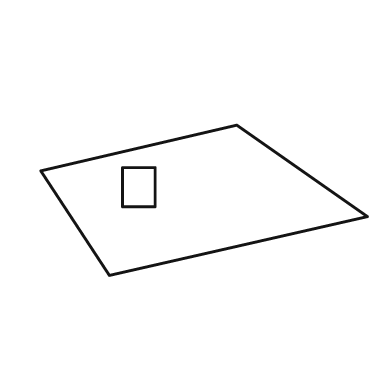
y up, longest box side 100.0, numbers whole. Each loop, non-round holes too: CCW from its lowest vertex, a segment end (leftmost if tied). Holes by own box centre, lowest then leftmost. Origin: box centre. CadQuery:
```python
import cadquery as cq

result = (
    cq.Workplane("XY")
    .moveTo(-29.0, -23.0)
    .lineTo(50.0, -5.0)
    .lineTo(10.0, 23.0)
    .lineTo(-50.0, 9.0)
    .close()
    .moveTo(-25.0, -2.0)
    .lineTo(-15.0, -2.0)
    .lineTo(-15.0, 10.0)
    .lineTo(-25.0, 10.0)
    .close()
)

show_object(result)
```